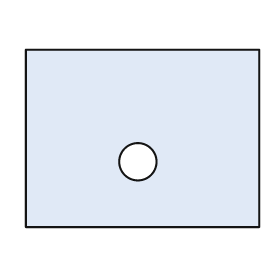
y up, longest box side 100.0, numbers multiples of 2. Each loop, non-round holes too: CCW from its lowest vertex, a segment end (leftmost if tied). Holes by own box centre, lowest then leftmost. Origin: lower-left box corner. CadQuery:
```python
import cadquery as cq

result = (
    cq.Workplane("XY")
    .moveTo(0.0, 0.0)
    .lineTo(100.0, 0.0)
    .lineTo(100.0, 76.0)
    .lineTo(0.0, 76.0)
    .close()
    .moveTo(48.0, 28.0)
    .circle(8.0)
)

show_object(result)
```